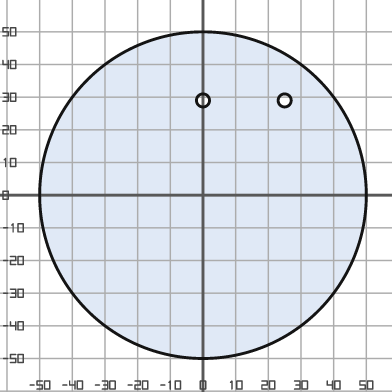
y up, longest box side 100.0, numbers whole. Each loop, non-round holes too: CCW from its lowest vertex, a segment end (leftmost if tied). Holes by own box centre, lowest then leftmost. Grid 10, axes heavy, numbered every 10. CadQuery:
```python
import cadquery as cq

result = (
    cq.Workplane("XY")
    .moveTo(0.0, 0.0)
    .circle(50.0)
    .moveTo(0.0, 29.0)
    .circle(2.0)
    .moveTo(25.0, 29.0)
    .circle(2.0)
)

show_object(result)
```